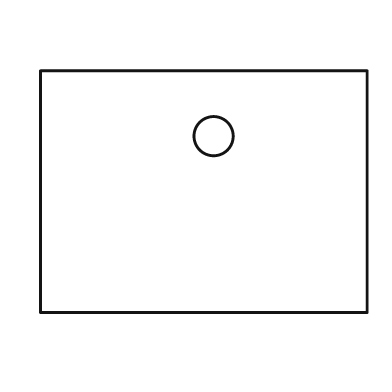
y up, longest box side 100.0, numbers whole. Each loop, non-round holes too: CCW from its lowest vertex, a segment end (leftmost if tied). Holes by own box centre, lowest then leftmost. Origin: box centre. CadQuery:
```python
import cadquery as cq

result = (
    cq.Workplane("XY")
    .moveTo(-50.0, -37.0)
    .lineTo(50.0, -37.0)
    .lineTo(50.0, 37.0)
    .lineTo(-50.0, 37.0)
    .close()
    .moveTo(3.0, 17.0)
    .circle(6.0)
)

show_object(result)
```